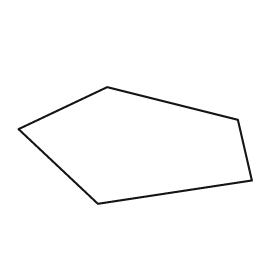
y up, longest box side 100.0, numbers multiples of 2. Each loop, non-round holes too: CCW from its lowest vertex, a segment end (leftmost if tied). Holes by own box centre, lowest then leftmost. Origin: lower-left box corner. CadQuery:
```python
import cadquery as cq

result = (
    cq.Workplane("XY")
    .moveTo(34.0, 0.0)
    .lineTo(100.0, 10.0)
    .lineTo(94.0, 36.0)
    .lineTo(38.0, 50.0)
    .lineTo(0.0, 32.0)
    .close()
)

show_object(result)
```